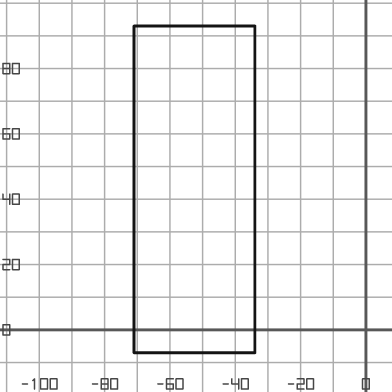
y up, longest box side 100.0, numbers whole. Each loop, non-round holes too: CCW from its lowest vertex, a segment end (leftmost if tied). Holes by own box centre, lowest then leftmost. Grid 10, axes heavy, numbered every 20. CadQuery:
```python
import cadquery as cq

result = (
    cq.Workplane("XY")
    .moveTo(-71.0, -7.0)
    .lineTo(-34.0, -7.0)
    .lineTo(-34.0, 93.0)
    .lineTo(-71.0, 93.0)
    .close()
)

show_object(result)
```